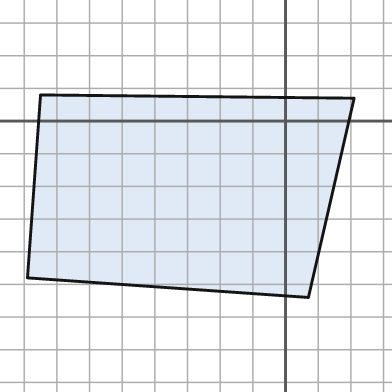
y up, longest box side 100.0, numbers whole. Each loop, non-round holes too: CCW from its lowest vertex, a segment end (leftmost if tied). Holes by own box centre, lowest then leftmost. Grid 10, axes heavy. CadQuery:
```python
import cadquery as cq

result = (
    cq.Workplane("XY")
    .moveTo(7.0, -54.0)
    .lineTo(21.0, 7.0)
    .lineTo(-75.0, 8.0)
    .lineTo(-79.0, -48.0)
    .close()
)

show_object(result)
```